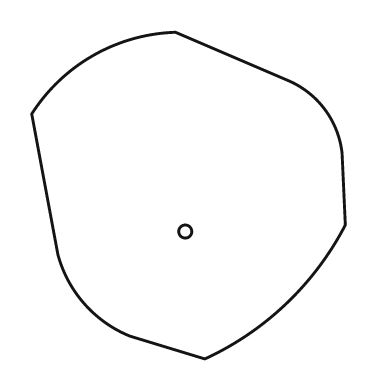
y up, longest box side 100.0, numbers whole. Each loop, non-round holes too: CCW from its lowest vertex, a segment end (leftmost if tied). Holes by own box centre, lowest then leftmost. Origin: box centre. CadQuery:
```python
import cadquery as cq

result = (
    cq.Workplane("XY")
    .moveTo(5.0, -50.0)
    .threePointArc((30.0, -33.0), (48.0, -9.0))
    .lineTo(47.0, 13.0)
    .threePointArc((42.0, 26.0), (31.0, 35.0))
    .lineTo(-4.0, 50.0)
    .threePointArc((-29.0, 43.0), (-48.0, 25.0))
    .lineTo(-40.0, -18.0)
    .threePointArc((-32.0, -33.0), (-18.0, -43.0))
    .close()
    .moveTo(-1.0, -11.0)
    .circle(2.0)
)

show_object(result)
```